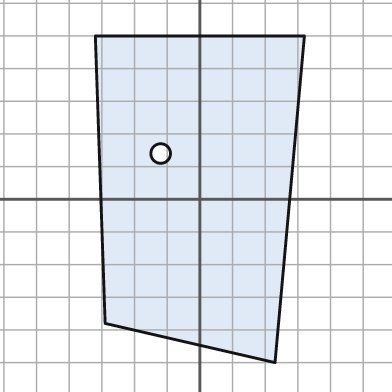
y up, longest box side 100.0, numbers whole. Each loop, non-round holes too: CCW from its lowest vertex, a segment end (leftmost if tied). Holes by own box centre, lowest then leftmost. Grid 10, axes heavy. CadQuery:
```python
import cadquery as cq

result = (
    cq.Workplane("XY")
    .moveTo(23.0, -50.0)
    .lineTo(32.0, 50.0)
    .lineTo(-32.0, 50.0)
    .lineTo(-29.0, -38.0)
    .close()
    .moveTo(-12.0, 14.0)
    .circle(3.0)
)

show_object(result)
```